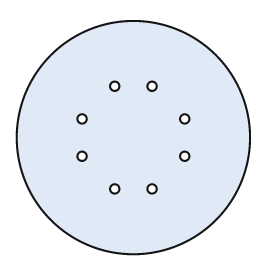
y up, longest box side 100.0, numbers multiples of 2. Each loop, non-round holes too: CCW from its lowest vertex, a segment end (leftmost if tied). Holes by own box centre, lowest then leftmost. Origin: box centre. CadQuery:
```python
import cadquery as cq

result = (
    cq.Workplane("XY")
    .moveTo(0.0, 0.0)
    .circle(50.0)
    .moveTo(-8.0, -22.0)
    .circle(2.0)
    .moveTo(8.0, -22.0)
    .circle(2.0)
    .moveTo(-22.0, -8.0)
    .circle(2.0)
    .moveTo(22.0, -8.0)
    .circle(2.0)
    .moveTo(-22.0, 8.0)
    .circle(2.0)
    .moveTo(22.0, 8.0)
    .circle(2.0)
    .moveTo(-8.0, 22.0)
    .circle(2.0)
    .moveTo(8.0, 22.0)
    .circle(2.0)
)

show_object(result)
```